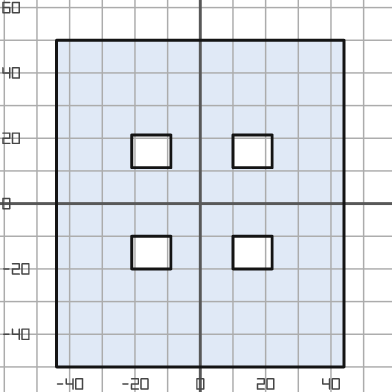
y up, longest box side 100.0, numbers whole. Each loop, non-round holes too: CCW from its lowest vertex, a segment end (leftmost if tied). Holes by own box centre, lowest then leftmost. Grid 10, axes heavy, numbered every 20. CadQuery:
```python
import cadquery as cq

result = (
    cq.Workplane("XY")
    .moveTo(-44.0, -50.0)
    .lineTo(44.0, -50.0)
    .lineTo(44.0, 50.0)
    .lineTo(-44.0, 50.0)
    .close()
    .moveTo(-21.0, -20.0)
    .lineTo(-9.0, -20.0)
    .lineTo(-9.0, -10.0)
    .lineTo(-21.0, -10.0)
    .close()
    .moveTo(10.0, -20.0)
    .lineTo(22.0, -20.0)
    .lineTo(22.0, -10.0)
    .lineTo(10.0, -10.0)
    .close()
    .moveTo(-21.0, 11.0)
    .lineTo(-9.0, 11.0)
    .lineTo(-9.0, 21.0)
    .lineTo(-21.0, 21.0)
    .close()
    .moveTo(10.0, 11.0)
    .lineTo(22.0, 11.0)
    .lineTo(22.0, 21.0)
    .lineTo(10.0, 21.0)
    .close()
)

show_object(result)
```